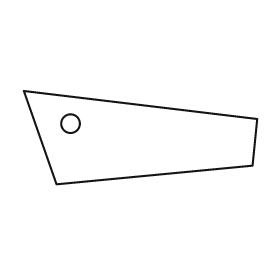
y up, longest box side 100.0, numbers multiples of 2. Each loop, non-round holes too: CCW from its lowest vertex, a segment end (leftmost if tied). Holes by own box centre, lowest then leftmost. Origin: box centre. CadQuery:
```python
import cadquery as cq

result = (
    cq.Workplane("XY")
    .moveTo(-36.0, -20.0)
    .lineTo(48.0, -12.0)
    .lineTo(50.0, 8.0)
    .lineTo(-50.0, 20.0)
    .close()
    .moveTo(-30.0, 6.0)
    .circle(4.0)
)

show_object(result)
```